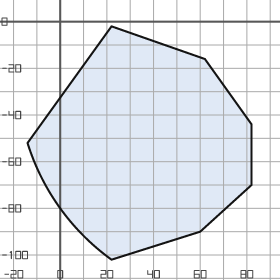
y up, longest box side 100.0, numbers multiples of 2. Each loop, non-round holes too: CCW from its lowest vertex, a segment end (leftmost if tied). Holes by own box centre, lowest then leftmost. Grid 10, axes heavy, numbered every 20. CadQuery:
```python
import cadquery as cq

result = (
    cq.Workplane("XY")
    .moveTo(22.0, -102.0)
    .lineTo(60.0, -90.0)
    .lineTo(82.0, -70.0)
    .lineTo(82.0, -44.0)
    .lineTo(62.0, -16.0)
    .lineTo(22.0, -2.0)
    .lineTo(-14.0, -52.0)
    .threePointArc((0.0, -80.0), (22.0, -102.0))
    .close()
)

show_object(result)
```